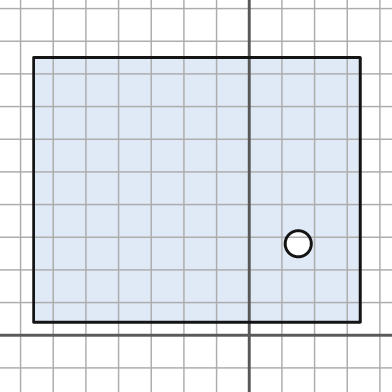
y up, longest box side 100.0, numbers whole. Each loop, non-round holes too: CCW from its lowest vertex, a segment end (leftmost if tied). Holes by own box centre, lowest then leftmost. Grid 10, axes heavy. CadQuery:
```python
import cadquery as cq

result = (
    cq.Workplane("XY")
    .moveTo(-66.0, 4.0)
    .lineTo(34.0, 4.0)
    .lineTo(34.0, 85.0)
    .lineTo(-66.0, 85.0)
    .close()
    .moveTo(15.0, 28.0)
    .circle(4.0)
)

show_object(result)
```